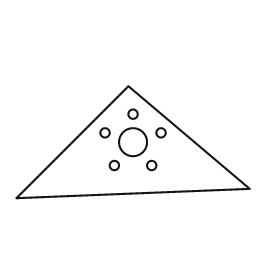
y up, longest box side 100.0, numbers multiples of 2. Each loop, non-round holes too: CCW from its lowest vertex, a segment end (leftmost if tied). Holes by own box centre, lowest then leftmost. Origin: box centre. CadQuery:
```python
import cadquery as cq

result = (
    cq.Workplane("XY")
    .moveTo(-50.0, -24.0)
    .lineTo(50.0, -20.0)
    .lineTo(-2.0, 24.0)
    .close()
    .moveTo(-8.0, -10.0)
    .circle(2.0)
    .moveTo(8.0, -10.0)
    .circle(2.0)
    .moveTo(0.0, 0.0)
    .circle(6.0)
    .moveTo(-12.0, 4.0)
    .circle(2.0)
    .moveTo(12.0, 4.0)
    .circle(2.0)
    .moveTo(0.0, 12.0)
    .circle(2.0)
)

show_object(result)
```